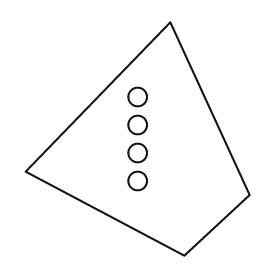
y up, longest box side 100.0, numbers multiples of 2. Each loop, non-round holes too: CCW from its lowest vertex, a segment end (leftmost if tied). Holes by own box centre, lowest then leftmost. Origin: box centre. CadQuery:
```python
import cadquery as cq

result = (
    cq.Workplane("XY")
    .moveTo(20.0, -50.0)
    .lineTo(48.0, -24.0)
    .lineTo(14.0, 50.0)
    .lineTo(-48.0, -14.0)
    .close()
    .moveTo(0.0, -18.0)
    .circle(4.0)
    .moveTo(0.0, -6.0)
    .circle(4.0)
    .moveTo(0.0, 6.0)
    .circle(4.0)
    .moveTo(0.0, 18.0)
    .circle(4.0)
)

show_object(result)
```